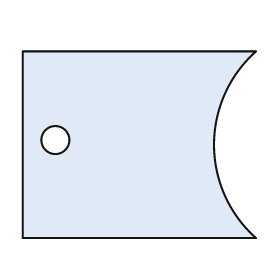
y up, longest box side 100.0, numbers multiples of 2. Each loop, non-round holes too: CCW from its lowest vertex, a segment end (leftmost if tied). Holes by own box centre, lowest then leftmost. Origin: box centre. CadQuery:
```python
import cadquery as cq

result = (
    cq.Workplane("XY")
    .moveTo(-50.0, -40.0)
    .lineTo(50.0, -40.0)
    .threePointArc((32.0, 0.0), (50.0, 40.0))
    .lineTo(-50.0, 40.0)
    .close()
    .moveTo(-36.0, 2.0)
    .circle(6.0)
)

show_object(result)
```